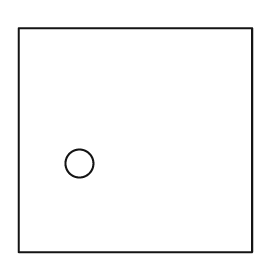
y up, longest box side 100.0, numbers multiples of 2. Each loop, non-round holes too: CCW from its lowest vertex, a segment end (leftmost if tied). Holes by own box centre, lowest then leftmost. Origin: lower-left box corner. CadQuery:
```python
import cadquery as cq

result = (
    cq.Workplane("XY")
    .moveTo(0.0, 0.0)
    .lineTo(100.0, 0.0)
    .lineTo(100.0, 96.0)
    .lineTo(0.0, 96.0)
    .close()
    .moveTo(26.0, 38.0)
    .circle(6.0)
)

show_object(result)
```